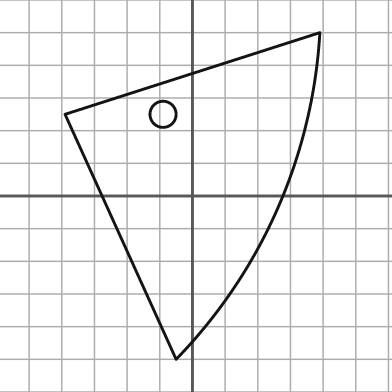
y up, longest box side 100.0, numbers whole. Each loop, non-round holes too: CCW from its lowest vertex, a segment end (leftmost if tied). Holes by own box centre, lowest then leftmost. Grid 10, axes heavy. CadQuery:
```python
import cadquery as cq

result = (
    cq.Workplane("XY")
    .moveTo(-5.0, -50.0)
    .threePointArc((26.0, -4.0), (39.0, 50.0))
    .lineTo(-39.0, 25.0)
    .close()
    .moveTo(-9.0, 25.0)
    .circle(4.0)
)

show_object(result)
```